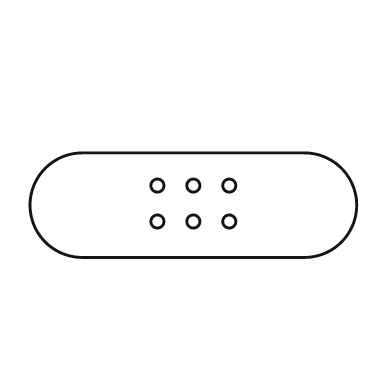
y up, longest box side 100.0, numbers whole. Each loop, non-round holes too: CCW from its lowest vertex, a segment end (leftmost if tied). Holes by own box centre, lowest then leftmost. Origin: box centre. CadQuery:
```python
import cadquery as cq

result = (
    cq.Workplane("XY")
    .moveTo(-34.0, -16.0)
    .lineTo(34.0, -16.0)
    .threePointArc((50.0, 0.0), (34.0, 16.0))
    .lineTo(-34.0, 16.0)
    .threePointArc((-50.0, 0.0), (-34.0, -16.0))
    .close()
    .moveTo(-11.0, -5.0)
    .circle(2.0)
    .moveTo(0.0, -5.0)
    .circle(2.0)
    .moveTo(11.0, -5.0)
    .circle(2.0)
    .moveTo(-11.0, 6.0)
    .circle(2.0)
    .moveTo(0.0, 6.0)
    .circle(2.0)
    .moveTo(11.0, 6.0)
    .circle(2.0)
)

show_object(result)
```